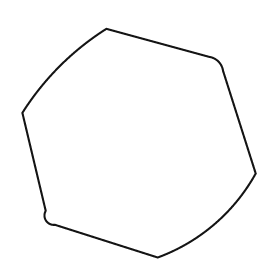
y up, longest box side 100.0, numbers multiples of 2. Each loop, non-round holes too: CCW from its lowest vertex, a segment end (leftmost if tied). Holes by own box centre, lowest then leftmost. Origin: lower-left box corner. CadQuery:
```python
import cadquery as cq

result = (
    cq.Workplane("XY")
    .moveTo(58.0, 0.0)
    .threePointArc((82.0, 14.0), (100.0, 36.0))
    .lineTo(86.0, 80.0)
    .threePointArc((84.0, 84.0), (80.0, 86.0))
    .lineTo(36.0, 98.0)
    .threePointArc((16.0, 82.0), (0.0, 62.0))
    .lineTo(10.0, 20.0)
    .threePointArc((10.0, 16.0), (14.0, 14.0))
    .close()
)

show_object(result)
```